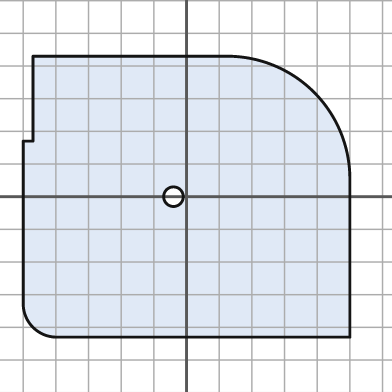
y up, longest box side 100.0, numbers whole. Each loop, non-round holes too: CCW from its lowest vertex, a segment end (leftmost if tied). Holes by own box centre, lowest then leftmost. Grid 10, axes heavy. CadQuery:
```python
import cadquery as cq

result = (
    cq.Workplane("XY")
    .moveTo(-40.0, -43.0)
    .lineTo(50.0, -43.0)
    .lineTo(50.0, 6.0)
    .threePointArc((39.0, 32.0), (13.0, 43.0))
    .lineTo(-47.0, 43.0)
    .lineTo(-47.0, 17.0)
    .lineTo(-50.0, 17.0)
    .lineTo(-50.0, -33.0)
    .threePointArc((-47.0, -40.0), (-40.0, -43.0))
    .close()
    .moveTo(-4.0, 0.0)
    .circle(3.0)
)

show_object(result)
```